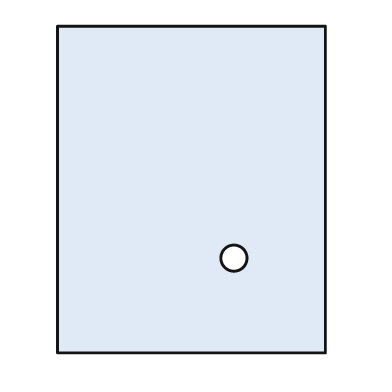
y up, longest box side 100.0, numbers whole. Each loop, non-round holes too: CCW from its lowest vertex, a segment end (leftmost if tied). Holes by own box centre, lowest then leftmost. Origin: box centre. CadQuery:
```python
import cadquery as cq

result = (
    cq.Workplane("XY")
    .moveTo(-41.0, -50.0)
    .lineTo(41.0, -50.0)
    .lineTo(41.0, 50.0)
    .lineTo(-41.0, 50.0)
    .close()
    .moveTo(13.0, -21.0)
    .circle(4.0)
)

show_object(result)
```